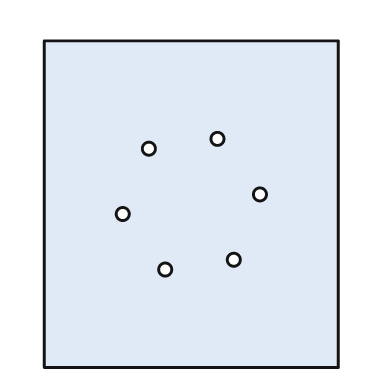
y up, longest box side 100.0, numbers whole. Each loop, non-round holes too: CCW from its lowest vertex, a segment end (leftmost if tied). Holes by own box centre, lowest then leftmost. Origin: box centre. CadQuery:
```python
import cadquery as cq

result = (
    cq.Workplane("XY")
    .moveTo(-45.0, -50.0)
    .lineTo(45.0, -50.0)
    .lineTo(45.0, 50.0)
    .lineTo(-45.0, 50.0)
    .close()
    .moveTo(-8.0, -20.0)
    .circle(2.0)
    .moveTo(13.0, -17.0)
    .circle(2.0)
    .moveTo(-21.0, -3.0)
    .circle(2.0)
    .moveTo(21.0, 3.0)
    .circle(2.0)
    .moveTo(-13.0, 17.0)
    .circle(2.0)
    .moveTo(8.0, 20.0)
    .circle(2.0)
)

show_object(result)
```